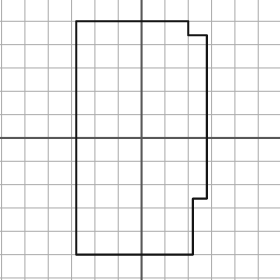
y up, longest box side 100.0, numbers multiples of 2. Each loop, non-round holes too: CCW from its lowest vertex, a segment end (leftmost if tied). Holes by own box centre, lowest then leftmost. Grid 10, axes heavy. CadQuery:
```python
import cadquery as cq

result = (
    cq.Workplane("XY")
    .moveTo(-28.0, -50.0)
    .lineTo(22.0, -50.0)
    .lineTo(22.0, -26.0)
    .lineTo(28.0, -26.0)
    .lineTo(28.0, 44.0)
    .lineTo(20.0, 44.0)
    .lineTo(20.0, 50.0)
    .lineTo(-28.0, 50.0)
    .close()
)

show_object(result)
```